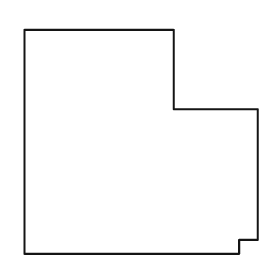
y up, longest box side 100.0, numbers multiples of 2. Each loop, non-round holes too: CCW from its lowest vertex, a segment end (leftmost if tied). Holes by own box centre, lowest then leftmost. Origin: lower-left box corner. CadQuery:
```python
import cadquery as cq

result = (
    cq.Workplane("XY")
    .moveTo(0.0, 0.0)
    .lineTo(92.0, 0.0)
    .lineTo(92.0, 6.0)
    .lineTo(100.0, 6.0)
    .lineTo(100.0, 62.0)
    .lineTo(64.0, 62.0)
    .lineTo(64.0, 96.0)
    .lineTo(0.0, 96.0)
    .close()
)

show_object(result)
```